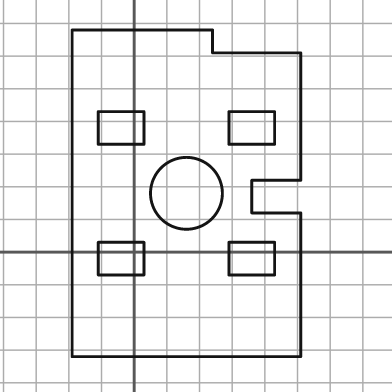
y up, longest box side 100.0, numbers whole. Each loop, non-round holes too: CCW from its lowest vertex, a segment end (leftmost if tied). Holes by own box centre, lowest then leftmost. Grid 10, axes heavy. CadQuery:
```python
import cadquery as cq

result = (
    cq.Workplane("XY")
    .moveTo(-19.0, -32.0)
    .lineTo(51.0, -32.0)
    .lineTo(51.0, 12.0)
    .lineTo(36.0, 12.0)
    .lineTo(36.0, 22.0)
    .lineTo(51.0, 22.0)
    .lineTo(51.0, 61.0)
    .lineTo(24.0, 61.0)
    .lineTo(24.0, 68.0)
    .lineTo(-19.0, 68.0)
    .close()
    .moveTo(-11.0, -7.0)
    .lineTo(3.0, -7.0)
    .lineTo(3.0, 3.0)
    .lineTo(-11.0, 3.0)
    .close()
    .moveTo(29.0, -7.0)
    .lineTo(43.0, -7.0)
    .lineTo(43.0, 3.0)
    .lineTo(29.0, 3.0)
    .close()
    .moveTo(16.0, 18.0)
    .circle(11.0)
    .moveTo(-11.0, 33.0)
    .lineTo(3.0, 33.0)
    .lineTo(3.0, 43.0)
    .lineTo(-11.0, 43.0)
    .close()
    .moveTo(29.0, 33.0)
    .lineTo(43.0, 33.0)
    .lineTo(43.0, 43.0)
    .lineTo(29.0, 43.0)
    .close()
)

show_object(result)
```